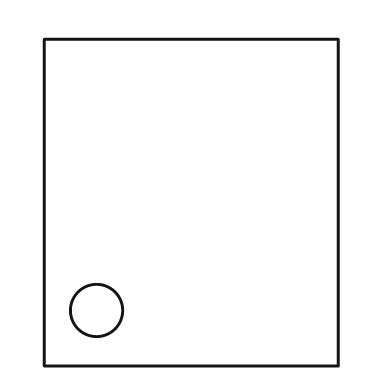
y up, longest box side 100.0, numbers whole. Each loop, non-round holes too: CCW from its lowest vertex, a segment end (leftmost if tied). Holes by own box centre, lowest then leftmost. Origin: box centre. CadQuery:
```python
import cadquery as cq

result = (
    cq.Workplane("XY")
    .moveTo(-45.0, -50.0)
    .lineTo(45.0, -50.0)
    .lineTo(45.0, 50.0)
    .lineTo(-45.0, 50.0)
    .close()
    .moveTo(-29.0, -33.0)
    .circle(8.0)
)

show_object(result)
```